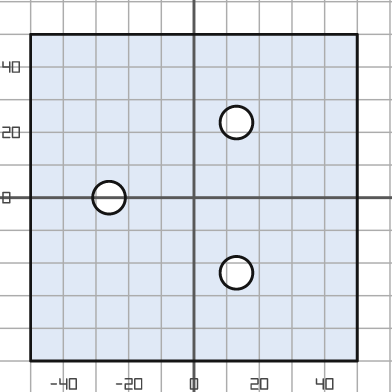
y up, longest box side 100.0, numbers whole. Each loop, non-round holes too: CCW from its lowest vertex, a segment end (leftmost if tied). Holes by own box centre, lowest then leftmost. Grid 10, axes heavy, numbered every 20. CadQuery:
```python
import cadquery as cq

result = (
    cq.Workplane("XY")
    .moveTo(-50.0, -50.0)
    .lineTo(50.0, -50.0)
    .lineTo(50.0, 50.0)
    .lineTo(-50.0, 50.0)
    .close()
    .moveTo(13.0, -23.0)
    .circle(5.0)
    .moveTo(-26.0, 0.0)
    .circle(5.0)
    .moveTo(13.0, 23.0)
    .circle(5.0)
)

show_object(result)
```